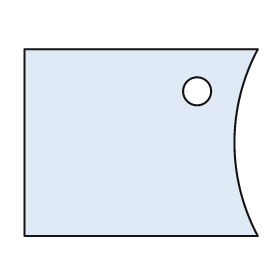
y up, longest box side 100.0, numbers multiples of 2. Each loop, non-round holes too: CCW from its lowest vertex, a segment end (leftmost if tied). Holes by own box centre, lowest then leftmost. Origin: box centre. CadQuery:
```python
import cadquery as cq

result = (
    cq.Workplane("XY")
    .moveTo(-50.0, -40.0)
    .lineTo(50.0, -40.0)
    .threePointArc((40.0, 0.0), (50.0, 40.0))
    .lineTo(-50.0, 40.0)
    .close()
    .moveTo(24.0, 22.0)
    .circle(6.0)
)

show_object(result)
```